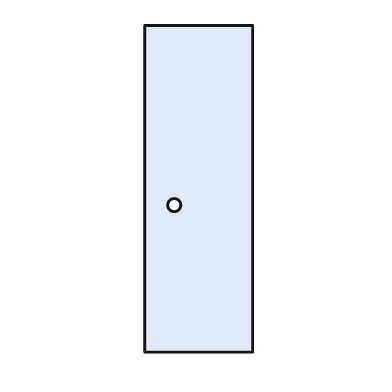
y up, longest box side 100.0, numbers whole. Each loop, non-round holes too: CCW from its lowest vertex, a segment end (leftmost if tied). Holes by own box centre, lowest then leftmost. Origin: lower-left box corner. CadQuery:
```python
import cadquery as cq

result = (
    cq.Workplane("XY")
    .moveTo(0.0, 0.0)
    .lineTo(33.0, 0.0)
    .lineTo(33.0, 100.0)
    .lineTo(0.0, 100.0)
    .close()
    .moveTo(9.0, 45.0)
    .circle(2.0)
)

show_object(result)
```